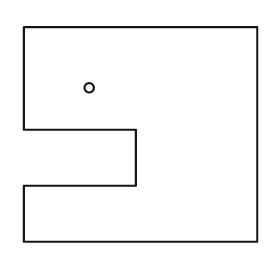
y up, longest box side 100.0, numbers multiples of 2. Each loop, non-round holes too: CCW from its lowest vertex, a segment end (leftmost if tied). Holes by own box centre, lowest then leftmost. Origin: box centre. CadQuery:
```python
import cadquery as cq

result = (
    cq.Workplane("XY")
    .moveTo(-50.0, -46.0)
    .lineTo(50.0, -46.0)
    .lineTo(50.0, 46.0)
    .lineTo(-50.0, 46.0)
    .lineTo(-50.0, 2.0)
    .lineTo(-2.0, 2.0)
    .lineTo(-2.0, -22.0)
    .lineTo(-50.0, -22.0)
    .close()
    .moveTo(-22.0, 20.0)
    .circle(2.0)
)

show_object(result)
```